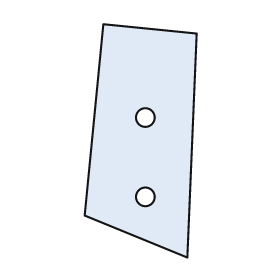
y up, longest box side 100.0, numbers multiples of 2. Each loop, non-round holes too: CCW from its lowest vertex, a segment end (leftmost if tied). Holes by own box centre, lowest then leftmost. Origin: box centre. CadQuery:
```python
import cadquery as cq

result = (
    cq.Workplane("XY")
    .moveTo(20.0, -50.0)
    .lineTo(24.0, 46.0)
    .lineTo(-16.0, 50.0)
    .lineTo(-24.0, -32.0)
    .close()
    .moveTo(2.0, -24.0)
    .circle(4.0)
    .moveTo(2.0, 10.0)
    .circle(4.0)
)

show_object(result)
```